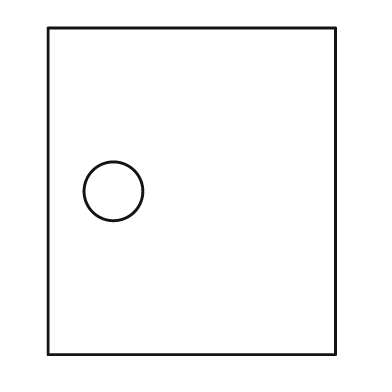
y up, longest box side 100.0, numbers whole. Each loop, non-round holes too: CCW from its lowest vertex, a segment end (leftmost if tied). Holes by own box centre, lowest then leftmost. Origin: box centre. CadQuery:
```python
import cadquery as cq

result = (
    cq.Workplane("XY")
    .moveTo(-44.0, -50.0)
    .lineTo(44.0, -50.0)
    .lineTo(44.0, 50.0)
    .lineTo(-44.0, 50.0)
    .close()
    .moveTo(-24.0, 0.0)
    .circle(9.0)
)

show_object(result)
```